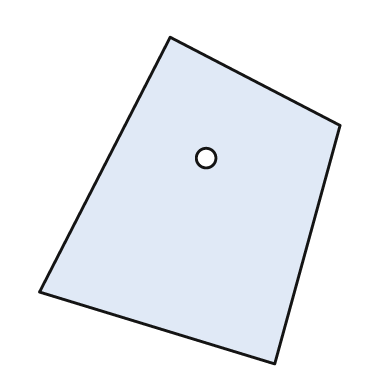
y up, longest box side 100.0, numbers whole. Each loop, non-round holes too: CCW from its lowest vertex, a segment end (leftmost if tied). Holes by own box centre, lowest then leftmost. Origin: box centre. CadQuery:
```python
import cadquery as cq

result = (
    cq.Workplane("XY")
    .moveTo(26.0, -50.0)
    .lineTo(46.0, 23.0)
    .lineTo(-6.0, 50.0)
    .lineTo(-46.0, -28.0)
    .close()
    .moveTo(5.0, 13.0)
    .circle(3.0)
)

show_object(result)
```